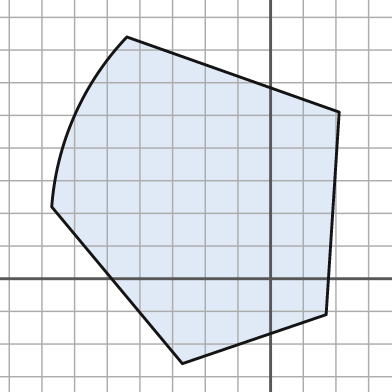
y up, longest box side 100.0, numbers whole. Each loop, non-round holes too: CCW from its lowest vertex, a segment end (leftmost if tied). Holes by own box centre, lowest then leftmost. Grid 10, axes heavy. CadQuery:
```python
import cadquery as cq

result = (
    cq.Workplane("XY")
    .moveTo(-27.0, -26.0)
    .lineTo(17.0, -11.0)
    .lineTo(21.0, 51.0)
    .lineTo(-44.0, 74.0)
    .threePointArc((-60.0, 50.0), (-67.0, 22.0))
    .close()
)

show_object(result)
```